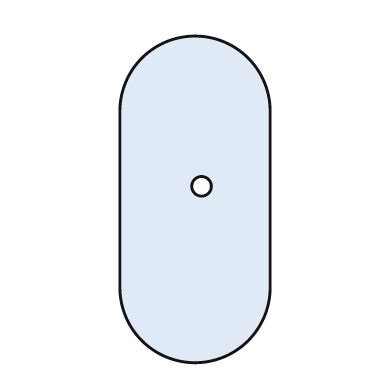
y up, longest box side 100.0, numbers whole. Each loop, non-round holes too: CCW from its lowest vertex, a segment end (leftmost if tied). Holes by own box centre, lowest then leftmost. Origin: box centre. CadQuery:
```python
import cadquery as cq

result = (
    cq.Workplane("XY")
    .moveTo(-23.0, -27.0)
    .threePointArc((0.0, -50.0), (23.0, -27.0))
    .lineTo(23.0, 27.0)
    .threePointArc((0.0, 50.0), (-23.0, 27.0))
    .close()
    .moveTo(2.0, 4.0)
    .circle(3.0)
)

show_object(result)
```